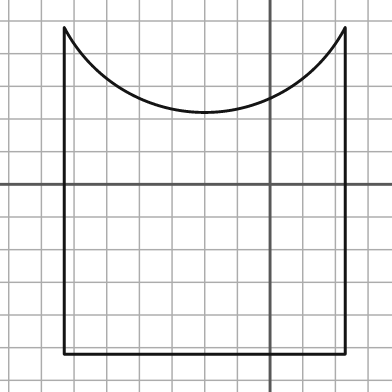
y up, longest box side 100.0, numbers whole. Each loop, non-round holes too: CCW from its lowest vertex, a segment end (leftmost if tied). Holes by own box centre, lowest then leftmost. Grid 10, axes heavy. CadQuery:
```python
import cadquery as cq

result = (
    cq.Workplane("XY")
    .moveTo(-63.0, -52.0)
    .lineTo(23.0, -52.0)
    .lineTo(23.0, 48.0)
    .threePointArc((-20.0, 22.0), (-63.0, 48.0))
    .close()
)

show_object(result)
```